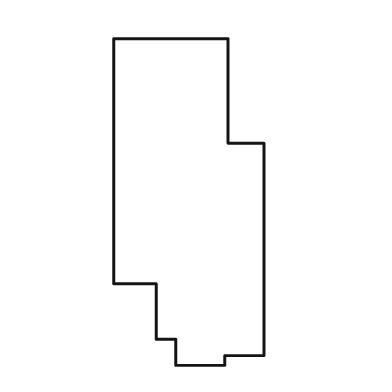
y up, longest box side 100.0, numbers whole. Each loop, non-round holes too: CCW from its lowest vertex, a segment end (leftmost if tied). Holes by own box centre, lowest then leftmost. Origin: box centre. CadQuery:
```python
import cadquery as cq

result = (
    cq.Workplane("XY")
    .moveTo(-4.0, -50.0)
    .lineTo(11.0, -50.0)
    .lineTo(11.0, -47.0)
    .lineTo(23.0, -47.0)
    .lineTo(23.0, 18.0)
    .lineTo(12.0, 18.0)
    .lineTo(12.0, 50.0)
    .lineTo(-23.0, 50.0)
    .lineTo(-23.0, -25.0)
    .lineTo(-10.0, -25.0)
    .lineTo(-10.0, -42.0)
    .lineTo(-4.0, -42.0)
    .close()
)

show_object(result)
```